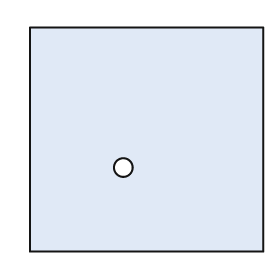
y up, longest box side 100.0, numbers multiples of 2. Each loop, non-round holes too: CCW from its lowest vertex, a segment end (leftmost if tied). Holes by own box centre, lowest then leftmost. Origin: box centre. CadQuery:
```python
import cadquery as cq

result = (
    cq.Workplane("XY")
    .moveTo(-50.0, -48.0)
    .lineTo(50.0, -48.0)
    .lineTo(50.0, 48.0)
    .lineTo(-50.0, 48.0)
    .close()
    .moveTo(-10.0, -12.0)
    .circle(4.0)
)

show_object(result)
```